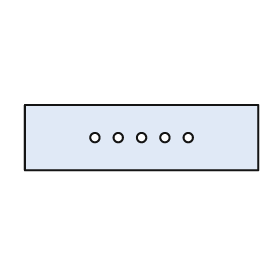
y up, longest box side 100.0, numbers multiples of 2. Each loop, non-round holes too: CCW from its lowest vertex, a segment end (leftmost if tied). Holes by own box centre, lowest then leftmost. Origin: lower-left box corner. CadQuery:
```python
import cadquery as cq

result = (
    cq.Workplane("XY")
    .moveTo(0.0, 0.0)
    .lineTo(100.0, 0.0)
    .lineTo(100.0, 28.0)
    .lineTo(0.0, 28.0)
    .close()
    .moveTo(30.0, 14.0)
    .circle(2.0)
    .moveTo(40.0, 14.0)
    .circle(2.0)
    .moveTo(50.0, 14.0)
    .circle(2.0)
    .moveTo(60.0, 14.0)
    .circle(2.0)
    .moveTo(70.0, 14.0)
    .circle(2.0)
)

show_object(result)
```